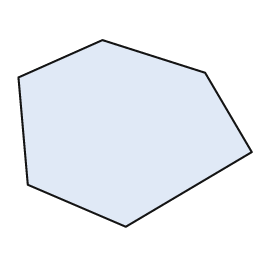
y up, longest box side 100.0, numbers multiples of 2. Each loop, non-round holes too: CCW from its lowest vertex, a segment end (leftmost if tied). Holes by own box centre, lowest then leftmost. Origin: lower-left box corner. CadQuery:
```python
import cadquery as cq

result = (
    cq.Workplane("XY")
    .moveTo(46.0, 0.0)
    .lineTo(100.0, 32.0)
    .lineTo(80.0, 66.0)
    .lineTo(36.0, 80.0)
    .lineTo(0.0, 64.0)
    .lineTo(4.0, 18.0)
    .close()
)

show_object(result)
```